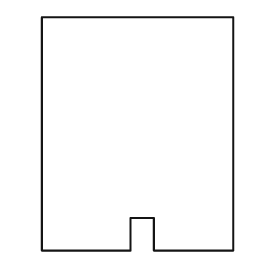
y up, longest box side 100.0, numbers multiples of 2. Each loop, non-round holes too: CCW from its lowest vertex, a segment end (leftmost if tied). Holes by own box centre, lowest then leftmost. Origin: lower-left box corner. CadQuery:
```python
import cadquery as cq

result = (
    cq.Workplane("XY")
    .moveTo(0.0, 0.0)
    .lineTo(38.0, 0.0)
    .lineTo(38.0, 14.0)
    .lineTo(48.0, 14.0)
    .lineTo(48.0, 0.0)
    .lineTo(82.0, 0.0)
    .lineTo(82.0, 100.0)
    .lineTo(0.0, 100.0)
    .close()
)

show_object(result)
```